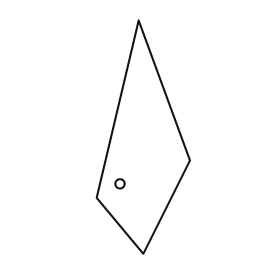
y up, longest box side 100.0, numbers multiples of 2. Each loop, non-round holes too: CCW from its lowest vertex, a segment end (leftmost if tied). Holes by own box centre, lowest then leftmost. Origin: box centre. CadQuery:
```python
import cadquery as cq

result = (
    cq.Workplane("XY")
    .moveTo(0.0, -50.0)
    .lineTo(20.0, -10.0)
    .lineTo(-2.0, 50.0)
    .lineTo(-20.0, -26.0)
    .close()
    .moveTo(-10.0, -20.0)
    .circle(2.0)
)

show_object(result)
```